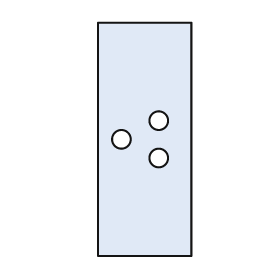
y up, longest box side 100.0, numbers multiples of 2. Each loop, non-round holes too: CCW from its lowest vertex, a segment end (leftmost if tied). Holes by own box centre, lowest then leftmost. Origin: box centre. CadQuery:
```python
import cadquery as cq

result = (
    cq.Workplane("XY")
    .moveTo(-20.0, -50.0)
    .lineTo(20.0, -50.0)
    .lineTo(20.0, 50.0)
    .lineTo(-20.0, 50.0)
    .close()
    .moveTo(6.0, -8.0)
    .circle(4.0)
    .moveTo(-10.0, 0.0)
    .circle(4.0)
    .moveTo(6.0, 8.0)
    .circle(4.0)
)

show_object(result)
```